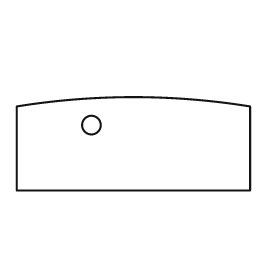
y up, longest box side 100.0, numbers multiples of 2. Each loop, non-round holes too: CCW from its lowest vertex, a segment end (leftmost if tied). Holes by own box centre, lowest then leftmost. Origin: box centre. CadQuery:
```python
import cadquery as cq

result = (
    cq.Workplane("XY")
    .moveTo(-50.0, -20.0)
    .lineTo(50.0, -20.0)
    .lineTo(50.0, 16.0)
    .threePointArc((0.0, 20.0), (-50.0, 16.0))
    .close()
    .moveTo(-18.0, 8.0)
    .circle(4.0)
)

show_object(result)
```